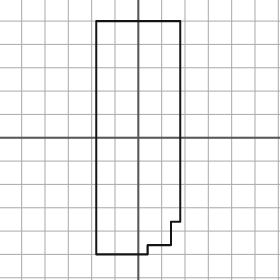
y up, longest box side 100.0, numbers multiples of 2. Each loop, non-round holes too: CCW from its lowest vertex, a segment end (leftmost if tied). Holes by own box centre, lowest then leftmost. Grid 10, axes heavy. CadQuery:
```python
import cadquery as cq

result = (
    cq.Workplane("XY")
    .moveTo(-18.0, -50.0)
    .lineTo(4.0, -50.0)
    .lineTo(4.0, -46.0)
    .lineTo(14.0, -46.0)
    .lineTo(14.0, -36.0)
    .lineTo(18.0, -36.0)
    .lineTo(18.0, 50.0)
    .lineTo(-18.0, 50.0)
    .close()
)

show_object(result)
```